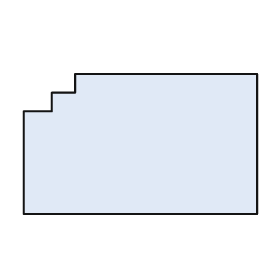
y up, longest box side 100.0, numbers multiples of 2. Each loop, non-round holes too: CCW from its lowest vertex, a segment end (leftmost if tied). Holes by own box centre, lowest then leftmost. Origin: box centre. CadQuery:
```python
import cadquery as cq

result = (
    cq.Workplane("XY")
    .moveTo(-50.0, -30.0)
    .lineTo(50.0, -30.0)
    .lineTo(50.0, 30.0)
    .lineTo(-28.0, 30.0)
    .lineTo(-28.0, 22.0)
    .lineTo(-38.0, 22.0)
    .lineTo(-38.0, 14.0)
    .lineTo(-50.0, 14.0)
    .close()
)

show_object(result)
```